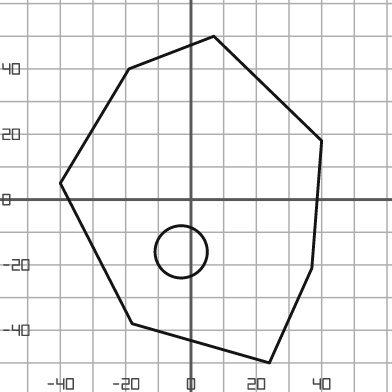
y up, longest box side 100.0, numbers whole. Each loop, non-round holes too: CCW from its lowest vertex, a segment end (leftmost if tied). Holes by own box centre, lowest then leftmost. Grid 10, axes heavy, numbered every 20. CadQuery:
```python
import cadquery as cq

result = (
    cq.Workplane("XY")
    .moveTo(24.0, -50.0)
    .lineTo(37.0, -21.0)
    .lineTo(40.0, 18.0)
    .lineTo(7.0, 50.0)
    .lineTo(-19.0, 40.0)
    .lineTo(-40.0, 5.0)
    .lineTo(-18.0, -38.0)
    .close()
    .moveTo(-3.0, -16.0)
    .circle(8.0)
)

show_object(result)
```